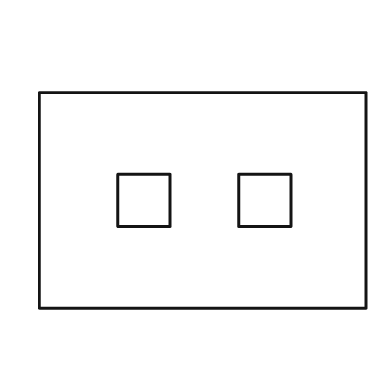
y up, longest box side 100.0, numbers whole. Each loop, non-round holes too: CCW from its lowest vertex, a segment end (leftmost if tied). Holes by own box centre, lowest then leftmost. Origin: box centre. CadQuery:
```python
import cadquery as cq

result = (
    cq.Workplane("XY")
    .moveTo(-50.0, -33.0)
    .lineTo(50.0, -33.0)
    .lineTo(50.0, 33.0)
    .lineTo(-50.0, 33.0)
    .close()
    .moveTo(-26.0, -8.0)
    .lineTo(-10.0, -8.0)
    .lineTo(-10.0, 8.0)
    .lineTo(-26.0, 8.0)
    .close()
    .moveTo(11.0, -8.0)
    .lineTo(27.0, -8.0)
    .lineTo(27.0, 8.0)
    .lineTo(11.0, 8.0)
    .close()
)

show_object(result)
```